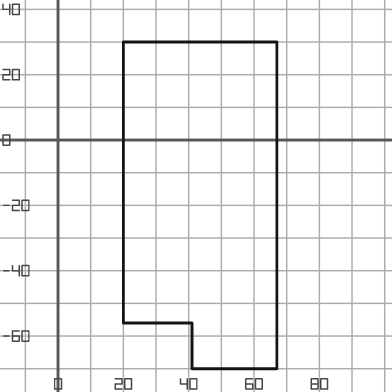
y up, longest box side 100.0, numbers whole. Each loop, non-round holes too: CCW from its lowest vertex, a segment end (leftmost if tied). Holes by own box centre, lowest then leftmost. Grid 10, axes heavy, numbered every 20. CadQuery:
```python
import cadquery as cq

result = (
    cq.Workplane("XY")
    .moveTo(41.0, -70.0)
    .lineTo(67.0, -70.0)
    .lineTo(67.0, 30.0)
    .lineTo(20.0, 30.0)
    .lineTo(20.0, -56.0)
    .lineTo(41.0, -56.0)
    .close()
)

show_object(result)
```